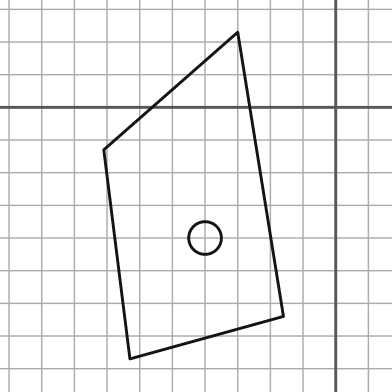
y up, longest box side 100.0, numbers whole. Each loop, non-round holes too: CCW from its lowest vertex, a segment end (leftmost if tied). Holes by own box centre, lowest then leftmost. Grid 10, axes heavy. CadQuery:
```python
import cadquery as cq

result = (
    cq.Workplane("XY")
    .moveTo(-63.0, -77.0)
    .lineTo(-16.0, -64.0)
    .lineTo(-30.0, 23.0)
    .lineTo(-71.0, -13.0)
    .close()
    .moveTo(-40.0, -40.0)
    .circle(5.0)
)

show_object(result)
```